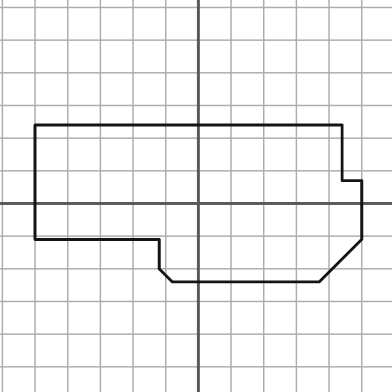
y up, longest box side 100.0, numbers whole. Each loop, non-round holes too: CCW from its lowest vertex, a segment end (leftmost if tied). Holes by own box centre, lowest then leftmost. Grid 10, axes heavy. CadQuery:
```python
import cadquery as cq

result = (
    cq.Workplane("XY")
    .moveTo(-8.0, -24.0)
    .lineTo(37.0, -24.0)
    .lineTo(50.0, -11.0)
    .lineTo(50.0, 7.0)
    .lineTo(44.0, 7.0)
    .lineTo(44.0, 24.0)
    .lineTo(-50.0, 24.0)
    .lineTo(-50.0, -11.0)
    .lineTo(-12.0, -11.0)
    .lineTo(-12.0, -20.0)
    .close()
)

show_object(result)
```